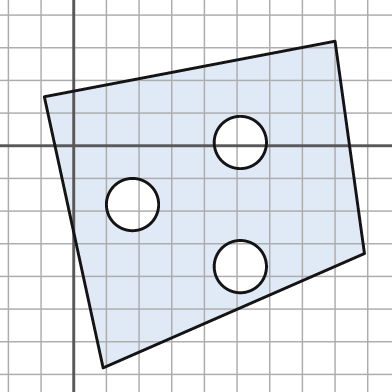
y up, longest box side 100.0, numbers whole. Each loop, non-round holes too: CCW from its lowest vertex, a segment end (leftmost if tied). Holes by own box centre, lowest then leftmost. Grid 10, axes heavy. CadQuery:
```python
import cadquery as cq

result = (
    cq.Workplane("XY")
    .moveTo(9.0, -68.0)
    .lineTo(89.0, -33.0)
    .lineTo(80.0, 32.0)
    .lineTo(-9.0, 15.0)
    .close()
    .moveTo(51.0, -37.0)
    .circle(8.0)
    .moveTo(18.0, -18.0)
    .circle(8.0)
    .moveTo(51.0, 1.0)
    .circle(8.0)
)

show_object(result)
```